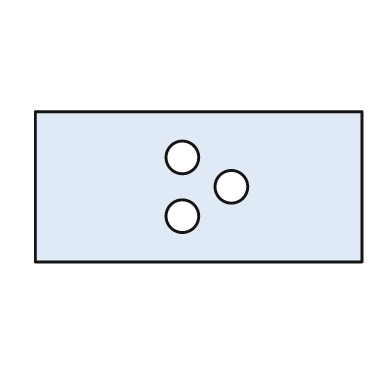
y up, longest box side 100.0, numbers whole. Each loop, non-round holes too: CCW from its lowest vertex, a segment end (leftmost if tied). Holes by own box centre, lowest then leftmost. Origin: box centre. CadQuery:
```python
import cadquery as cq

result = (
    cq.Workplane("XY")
    .moveTo(-50.0, -23.0)
    .lineTo(50.0, -23.0)
    .lineTo(50.0, 23.0)
    .lineTo(-50.0, 23.0)
    .close()
    .moveTo(-5.0, -9.0)
    .circle(5.0)
    .moveTo(10.0, 0.0)
    .circle(5.0)
    .moveTo(-5.0, 9.0)
    .circle(5.0)
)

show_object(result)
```